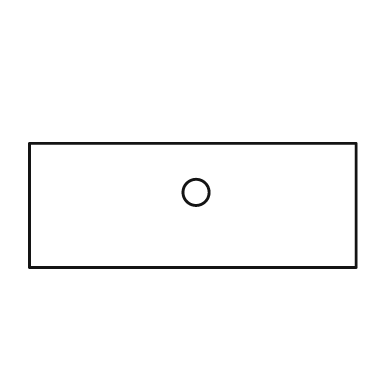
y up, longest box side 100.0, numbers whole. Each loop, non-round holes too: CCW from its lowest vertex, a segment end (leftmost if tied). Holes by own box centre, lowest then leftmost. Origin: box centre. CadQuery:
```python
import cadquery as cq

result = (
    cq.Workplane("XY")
    .moveTo(-50.0, -19.0)
    .lineTo(50.0, -19.0)
    .lineTo(50.0, 19.0)
    .lineTo(-50.0, 19.0)
    .close()
    .moveTo(1.0, 4.0)
    .circle(4.0)
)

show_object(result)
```